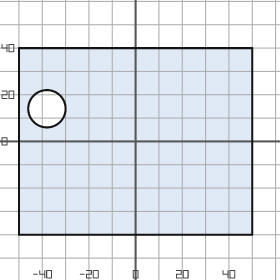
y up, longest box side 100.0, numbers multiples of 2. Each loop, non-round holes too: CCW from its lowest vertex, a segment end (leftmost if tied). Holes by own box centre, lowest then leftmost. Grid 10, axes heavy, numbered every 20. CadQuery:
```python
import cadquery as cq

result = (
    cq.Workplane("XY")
    .moveTo(-50.0, -40.0)
    .lineTo(50.0, -40.0)
    .lineTo(50.0, 40.0)
    .lineTo(-50.0, 40.0)
    .close()
    .moveTo(-38.0, 14.0)
    .circle(8.0)
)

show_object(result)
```